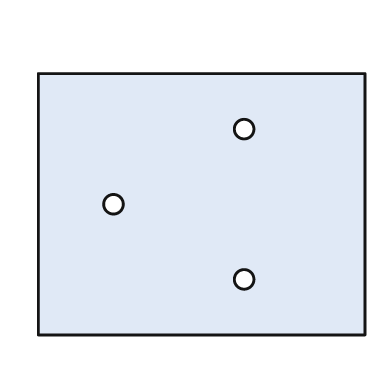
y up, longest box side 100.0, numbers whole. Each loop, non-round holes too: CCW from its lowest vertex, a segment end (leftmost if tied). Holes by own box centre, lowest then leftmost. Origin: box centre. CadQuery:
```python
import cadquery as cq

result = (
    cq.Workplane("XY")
    .moveTo(-50.0, -40.0)
    .lineTo(50.0, -40.0)
    .lineTo(50.0, 40.0)
    .lineTo(-50.0, 40.0)
    .close()
    .moveTo(13.0, -23.0)
    .circle(3.0)
    .moveTo(-27.0, 0.0)
    .circle(3.0)
    .moveTo(13.0, 23.0)
    .circle(3.0)
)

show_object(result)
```